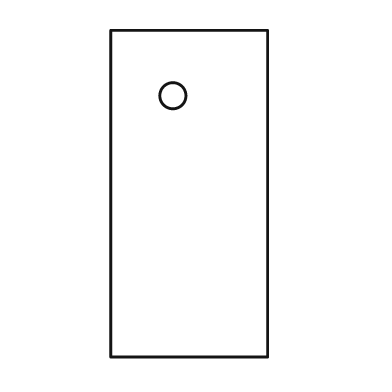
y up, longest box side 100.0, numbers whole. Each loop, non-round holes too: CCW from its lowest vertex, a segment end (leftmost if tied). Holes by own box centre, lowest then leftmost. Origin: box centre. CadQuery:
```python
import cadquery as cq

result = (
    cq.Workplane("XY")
    .moveTo(-24.0, -50.0)
    .lineTo(24.0, -50.0)
    .lineTo(24.0, 50.0)
    .lineTo(-24.0, 50.0)
    .close()
    .moveTo(-5.0, 30.0)
    .circle(4.0)
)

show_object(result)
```